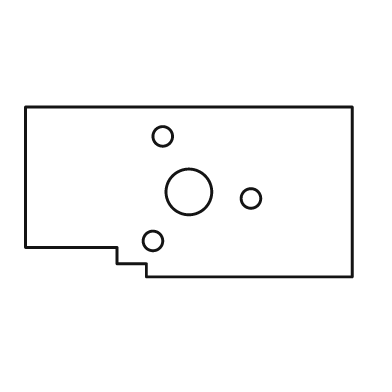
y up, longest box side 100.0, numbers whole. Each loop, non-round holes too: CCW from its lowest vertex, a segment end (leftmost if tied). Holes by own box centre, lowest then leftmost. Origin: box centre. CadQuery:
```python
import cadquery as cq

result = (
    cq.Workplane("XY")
    .moveTo(-13.0, -26.0)
    .lineTo(50.0, -26.0)
    .lineTo(50.0, 26.0)
    .lineTo(-50.0, 26.0)
    .lineTo(-50.0, -17.0)
    .lineTo(-22.0, -17.0)
    .lineTo(-22.0, -22.0)
    .lineTo(-13.0, -22.0)
    .close()
    .moveTo(-11.0, -15.0)
    .circle(3.0)
    .moveTo(19.0, -2.0)
    .circle(3.0)
    .moveTo(0.0, 0.0)
    .circle(7.0)
    .moveTo(-8.0, 17.0)
    .circle(3.0)
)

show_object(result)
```